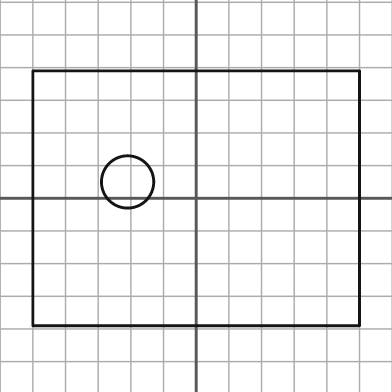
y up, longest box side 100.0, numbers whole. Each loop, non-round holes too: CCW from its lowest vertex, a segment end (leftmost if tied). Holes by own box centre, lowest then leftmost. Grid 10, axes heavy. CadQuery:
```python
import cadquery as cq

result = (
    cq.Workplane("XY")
    .moveTo(-50.0, -39.0)
    .lineTo(50.0, -39.0)
    .lineTo(50.0, 39.0)
    .lineTo(-50.0, 39.0)
    .close()
    .moveTo(-21.0, 5.0)
    .circle(8.0)
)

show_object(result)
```